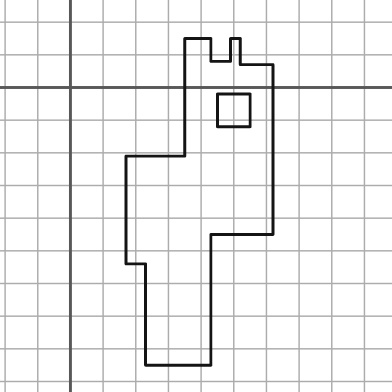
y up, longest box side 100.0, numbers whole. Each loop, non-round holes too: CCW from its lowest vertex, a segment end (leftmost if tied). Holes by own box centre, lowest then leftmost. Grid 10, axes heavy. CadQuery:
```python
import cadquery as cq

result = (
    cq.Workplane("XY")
    .moveTo(23.0, -85.0)
    .lineTo(43.0, -85.0)
    .lineTo(43.0, -45.0)
    .lineTo(62.0, -45.0)
    .lineTo(62.0, 7.0)
    .lineTo(52.0, 7.0)
    .lineTo(52.0, 15.0)
    .lineTo(49.0, 15.0)
    .lineTo(49.0, 8.0)
    .lineTo(43.0, 8.0)
    .lineTo(43.0, 15.0)
    .lineTo(35.0, 15.0)
    .lineTo(35.0, -21.0)
    .lineTo(17.0, -21.0)
    .lineTo(17.0, -54.0)
    .lineTo(23.0, -54.0)
    .close()
    .moveTo(45.0, -12.0)
    .lineTo(55.0, -12.0)
    .lineTo(55.0, -2.0)
    .lineTo(45.0, -2.0)
    .close()
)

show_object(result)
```